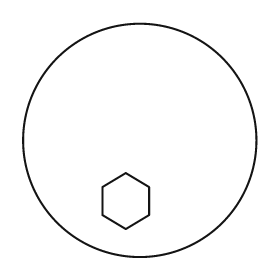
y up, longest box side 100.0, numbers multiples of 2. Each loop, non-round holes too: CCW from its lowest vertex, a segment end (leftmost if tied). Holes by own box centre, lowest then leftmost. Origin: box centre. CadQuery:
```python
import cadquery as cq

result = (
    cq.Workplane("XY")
    .moveTo(0.0, 0.0)
    .circle(50.0)
    .moveTo(-6.0, -38.0)
    .lineTo(4.0, -32.0)
    .lineTo(4.0, -20.0)
    .lineTo(-6.0, -14.0)
    .lineTo(-16.0, -20.0)
    .lineTo(-16.0, -32.0)
    .close()
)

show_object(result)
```